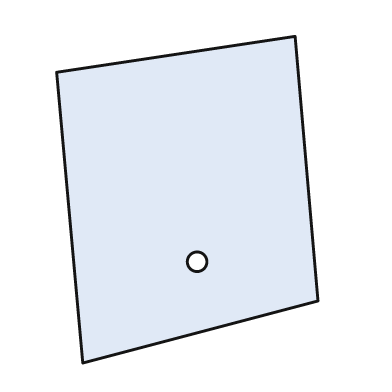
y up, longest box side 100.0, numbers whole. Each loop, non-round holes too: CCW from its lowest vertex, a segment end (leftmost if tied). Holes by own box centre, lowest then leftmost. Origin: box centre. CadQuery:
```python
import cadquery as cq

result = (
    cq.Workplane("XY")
    .moveTo(-32.0, -50.0)
    .lineTo(40.0, -31.0)
    .lineTo(33.0, 50.0)
    .lineTo(-40.0, 39.0)
    .close()
    .moveTo(3.0, -19.0)
    .circle(3.0)
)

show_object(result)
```